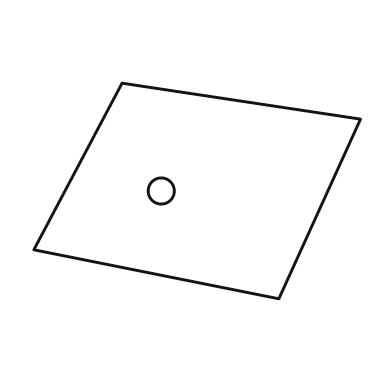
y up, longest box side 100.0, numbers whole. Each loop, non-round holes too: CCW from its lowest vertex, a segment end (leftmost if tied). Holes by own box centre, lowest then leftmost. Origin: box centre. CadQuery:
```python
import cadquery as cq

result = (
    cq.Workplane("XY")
    .moveTo(25.0, -33.0)
    .lineTo(50.0, 22.0)
    .lineTo(-23.0, 33.0)
    .lineTo(-50.0, -18.0)
    .close()
    .moveTo(-11.0, 0.0)
    .circle(4.0)
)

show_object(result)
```